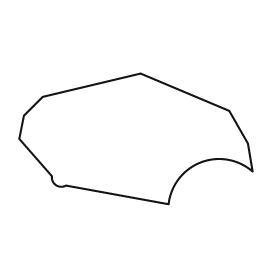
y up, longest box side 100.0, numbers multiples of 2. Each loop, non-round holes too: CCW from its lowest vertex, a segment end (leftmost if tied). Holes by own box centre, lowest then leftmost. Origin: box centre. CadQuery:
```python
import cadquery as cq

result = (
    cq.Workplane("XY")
    .moveTo(14.0, -28.0)
    .threePointArc((28.0, -10.0), (50.0, -14.0))
    .lineTo(48.0, -2.0)
    .lineTo(40.0, 12.0)
    .lineTo(2.0, 28.0)
    .lineTo(-40.0, 18.0)
    .lineTo(-48.0, 10.0)
    .lineTo(-50.0, 0.0)
    .lineTo(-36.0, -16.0)
    .threePointArc((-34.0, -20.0), (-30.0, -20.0))
    .close()
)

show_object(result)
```